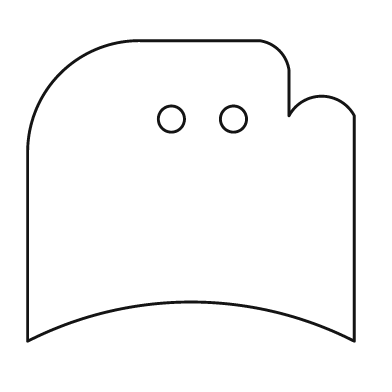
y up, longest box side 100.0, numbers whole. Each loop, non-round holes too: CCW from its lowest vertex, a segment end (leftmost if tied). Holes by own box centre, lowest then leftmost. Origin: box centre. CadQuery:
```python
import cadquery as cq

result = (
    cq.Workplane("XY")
    .moveTo(-50.0, -46.0)
    .threePointArc((0.0, -34.0), (50.0, -46.0))
    .lineTo(50.0, 23.0)
    .threePointArc((40.0, 29.0), (30.0, 23.0))
    .lineTo(30.0, 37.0)
    .threePointArc((27.0, 43.0), (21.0, 46.0))
    .lineTo(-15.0, 46.0)
    .threePointArc((-40.0, 36.0), (-50.0, 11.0))
    .close()
    .moveTo(-6.0, 22.0)
    .circle(4.0)
    .moveTo(13.0, 22.0)
    .circle(4.0)
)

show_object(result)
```